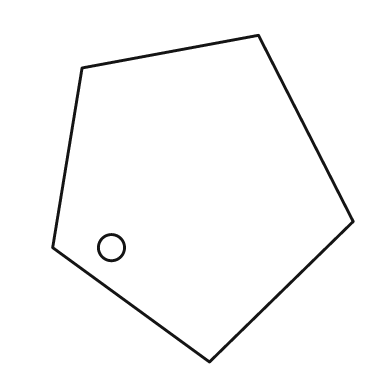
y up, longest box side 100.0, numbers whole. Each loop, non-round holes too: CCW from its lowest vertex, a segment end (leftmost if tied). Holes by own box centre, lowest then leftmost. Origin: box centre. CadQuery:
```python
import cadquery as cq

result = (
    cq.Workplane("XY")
    .moveTo(2.0, -50.0)
    .lineTo(46.0, -7.0)
    .lineTo(17.0, 50.0)
    .lineTo(-37.0, 40.0)
    .lineTo(-46.0, -15.0)
    .close()
    .moveTo(-28.0, -15.0)
    .circle(4.0)
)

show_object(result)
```